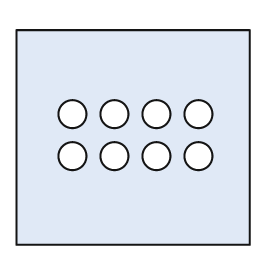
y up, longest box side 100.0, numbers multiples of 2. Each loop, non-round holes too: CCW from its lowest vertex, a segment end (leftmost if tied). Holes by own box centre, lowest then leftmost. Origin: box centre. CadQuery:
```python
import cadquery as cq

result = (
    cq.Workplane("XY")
    .moveTo(-50.0, -46.0)
    .lineTo(50.0, -46.0)
    .lineTo(50.0, 46.0)
    .lineTo(-50.0, 46.0)
    .close()
    .moveTo(-26.0, -8.0)
    .circle(6.0)
    .moveTo(-8.0, -8.0)
    .circle(6.0)
    .moveTo(10.0, -8.0)
    .circle(6.0)
    .moveTo(28.0, -8.0)
    .circle(6.0)
    .moveTo(-26.0, 10.0)
    .circle(6.0)
    .moveTo(-8.0, 10.0)
    .circle(6.0)
    .moveTo(10.0, 10.0)
    .circle(6.0)
    .moveTo(28.0, 10.0)
    .circle(6.0)
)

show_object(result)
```